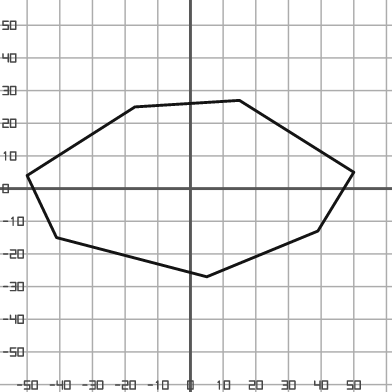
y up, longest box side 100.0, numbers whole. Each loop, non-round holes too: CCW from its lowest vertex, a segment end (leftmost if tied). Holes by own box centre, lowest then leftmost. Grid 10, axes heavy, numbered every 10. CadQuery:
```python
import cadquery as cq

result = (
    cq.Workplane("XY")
    .moveTo(5.0, -27.0)
    .lineTo(39.0, -13.0)
    .lineTo(50.0, 5.0)
    .lineTo(15.0, 27.0)
    .lineTo(-17.0, 25.0)
    .lineTo(-50.0, 4.0)
    .lineTo(-41.0, -15.0)
    .close()
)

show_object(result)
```